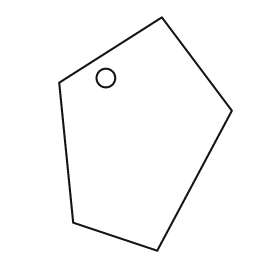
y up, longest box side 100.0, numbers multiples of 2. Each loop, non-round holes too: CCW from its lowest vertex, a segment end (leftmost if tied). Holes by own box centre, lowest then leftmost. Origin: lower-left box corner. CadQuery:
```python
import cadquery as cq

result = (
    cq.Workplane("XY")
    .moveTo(42.0, 0.0)
    .lineTo(74.0, 60.0)
    .lineTo(44.0, 100.0)
    .lineTo(0.0, 72.0)
    .lineTo(6.0, 12.0)
    .close()
    .moveTo(20.0, 74.0)
    .circle(4.0)
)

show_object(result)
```